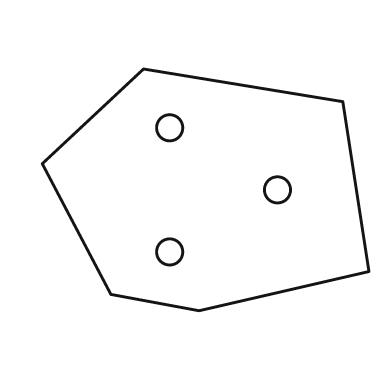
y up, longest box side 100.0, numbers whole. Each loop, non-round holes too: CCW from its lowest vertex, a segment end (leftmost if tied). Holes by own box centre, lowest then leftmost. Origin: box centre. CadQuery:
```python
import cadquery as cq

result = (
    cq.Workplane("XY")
    .moveTo(-2.0, -37.0)
    .lineTo(50.0, -25.0)
    .lineTo(42.0, 27.0)
    .lineTo(-19.0, 37.0)
    .lineTo(-50.0, 8.0)
    .lineTo(-29.0, -32.0)
    .close()
    .moveTo(-11.0, -19.0)
    .circle(4.0)
    .moveTo(22.0, 0.0)
    .circle(4.0)
    .moveTo(-11.0, 19.0)
    .circle(4.0)
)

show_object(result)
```